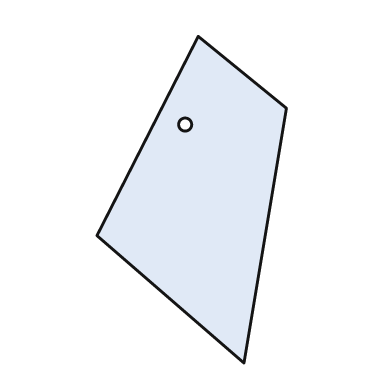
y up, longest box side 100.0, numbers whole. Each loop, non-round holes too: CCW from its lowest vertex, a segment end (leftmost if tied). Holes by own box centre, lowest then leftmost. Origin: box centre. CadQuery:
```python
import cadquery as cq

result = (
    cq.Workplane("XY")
    .moveTo(16.0, -50.0)
    .lineTo(29.0, 28.0)
    .lineTo(2.0, 50.0)
    .lineTo(-29.0, -11.0)
    .close()
    .moveTo(-2.0, 23.0)
    .circle(2.0)
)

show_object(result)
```